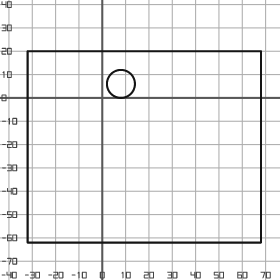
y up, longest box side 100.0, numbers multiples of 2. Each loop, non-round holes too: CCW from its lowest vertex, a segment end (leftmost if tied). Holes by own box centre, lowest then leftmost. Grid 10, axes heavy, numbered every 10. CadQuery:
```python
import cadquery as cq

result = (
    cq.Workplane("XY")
    .moveTo(-32.0, -62.0)
    .lineTo(68.0, -62.0)
    .lineTo(68.0, 20.0)
    .lineTo(-32.0, 20.0)
    .close()
    .moveTo(8.0, 6.0)
    .circle(6.0)
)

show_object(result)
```